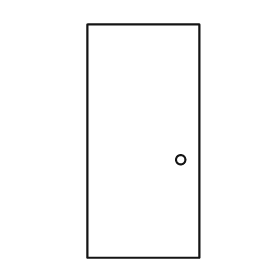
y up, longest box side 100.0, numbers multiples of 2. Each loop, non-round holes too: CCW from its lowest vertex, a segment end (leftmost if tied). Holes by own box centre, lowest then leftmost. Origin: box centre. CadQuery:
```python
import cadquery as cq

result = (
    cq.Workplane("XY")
    .moveTo(-24.0, -50.0)
    .lineTo(24.0, -50.0)
    .lineTo(24.0, 50.0)
    .lineTo(-24.0, 50.0)
    .close()
    .moveTo(16.0, -8.0)
    .circle(2.0)
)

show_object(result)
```